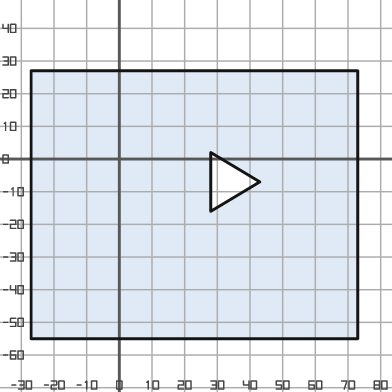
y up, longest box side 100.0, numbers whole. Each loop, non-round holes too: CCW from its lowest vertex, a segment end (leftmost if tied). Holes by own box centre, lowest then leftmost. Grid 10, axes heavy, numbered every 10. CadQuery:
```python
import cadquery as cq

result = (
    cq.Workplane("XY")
    .moveTo(-27.0, -55.0)
    .lineTo(73.0, -55.0)
    .lineTo(73.0, 27.0)
    .lineTo(-27.0, 27.0)
    .close()
    .moveTo(28.0, -16.0)
    .lineTo(43.0, -7.0)
    .lineTo(28.0, 2.0)
    .close()
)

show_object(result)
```